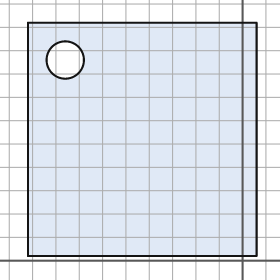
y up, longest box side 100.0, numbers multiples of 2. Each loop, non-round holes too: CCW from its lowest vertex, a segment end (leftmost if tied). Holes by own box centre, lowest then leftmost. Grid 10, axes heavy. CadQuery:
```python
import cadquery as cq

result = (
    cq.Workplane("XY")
    .moveTo(-92.0, 2.0)
    .lineTo(6.0, 2.0)
    .lineTo(6.0, 102.0)
    .lineTo(-92.0, 102.0)
    .close()
    .moveTo(-76.0, 86.0)
    .circle(8.0)
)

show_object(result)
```